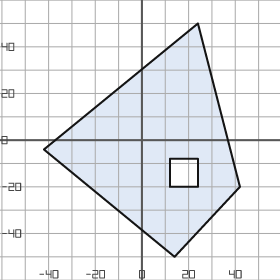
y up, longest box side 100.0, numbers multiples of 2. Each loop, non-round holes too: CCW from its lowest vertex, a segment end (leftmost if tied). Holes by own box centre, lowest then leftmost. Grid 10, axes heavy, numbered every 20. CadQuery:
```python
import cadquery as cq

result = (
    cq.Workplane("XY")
    .moveTo(14.0, -50.0)
    .lineTo(42.0, -20.0)
    .lineTo(24.0, 50.0)
    .lineTo(-42.0, -4.0)
    .close()
    .moveTo(12.0, -20.0)
    .lineTo(24.0, -20.0)
    .lineTo(24.0, -8.0)
    .lineTo(12.0, -8.0)
    .close()
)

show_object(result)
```